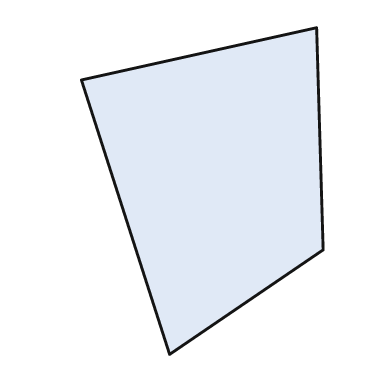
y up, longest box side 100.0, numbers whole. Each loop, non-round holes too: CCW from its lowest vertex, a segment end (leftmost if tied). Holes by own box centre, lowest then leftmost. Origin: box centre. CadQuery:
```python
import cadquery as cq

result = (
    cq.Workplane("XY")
    .moveTo(-10.0, -50.0)
    .lineTo(37.0, -18.0)
    .lineTo(35.0, 50.0)
    .lineTo(-37.0, 34.0)
    .close()
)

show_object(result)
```